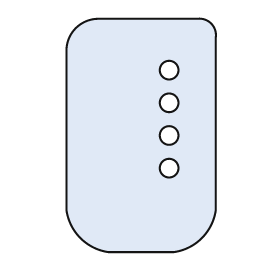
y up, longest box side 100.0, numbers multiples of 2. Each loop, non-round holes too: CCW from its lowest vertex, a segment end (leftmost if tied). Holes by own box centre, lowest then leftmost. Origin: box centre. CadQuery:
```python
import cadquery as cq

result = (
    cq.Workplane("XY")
    .moveTo(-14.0, -50.0)
    .lineTo(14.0, -50.0)
    .threePointArc((26.0, -44.0), (32.0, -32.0))
    .lineTo(32.0, 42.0)
    .threePointArc((30.0, 48.0), (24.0, 50.0))
    .lineTo(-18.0, 50.0)
    .threePointArc((-28.0, 46.0), (-32.0, 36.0))
    .lineTo(-32.0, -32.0)
    .threePointArc((-26.0, -44.0), (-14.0, -50.0))
    .close()
    .moveTo(12.0, -14.0)
    .circle(4.0)
    .moveTo(12.0, 0.0)
    .circle(4.0)
    .moveTo(12.0, 14.0)
    .circle(4.0)
    .moveTo(12.0, 28.0)
    .circle(4.0)
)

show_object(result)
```